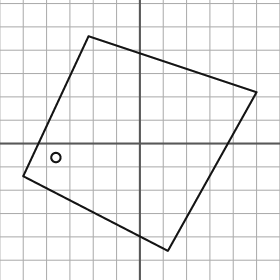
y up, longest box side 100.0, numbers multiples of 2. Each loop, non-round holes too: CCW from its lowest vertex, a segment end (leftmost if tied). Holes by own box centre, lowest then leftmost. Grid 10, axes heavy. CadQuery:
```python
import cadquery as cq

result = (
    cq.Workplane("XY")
    .moveTo(12.0, -46.0)
    .lineTo(50.0, 22.0)
    .lineTo(-22.0, 46.0)
    .lineTo(-50.0, -14.0)
    .close()
    .moveTo(-36.0, -6.0)
    .circle(2.0)
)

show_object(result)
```